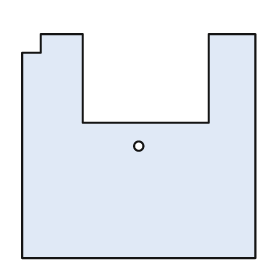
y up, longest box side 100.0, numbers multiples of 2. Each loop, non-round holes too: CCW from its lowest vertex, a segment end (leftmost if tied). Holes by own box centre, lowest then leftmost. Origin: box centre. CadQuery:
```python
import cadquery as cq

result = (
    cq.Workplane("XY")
    .moveTo(-50.0, -48.0)
    .lineTo(50.0, -48.0)
    .lineTo(50.0, 48.0)
    .lineTo(30.0, 48.0)
    .lineTo(30.0, 10.0)
    .lineTo(-24.0, 10.0)
    .lineTo(-24.0, 48.0)
    .lineTo(-42.0, 48.0)
    .lineTo(-42.0, 40.0)
    .lineTo(-50.0, 40.0)
    .close()
    .moveTo(0.0, 0.0)
    .circle(2.0)
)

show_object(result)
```